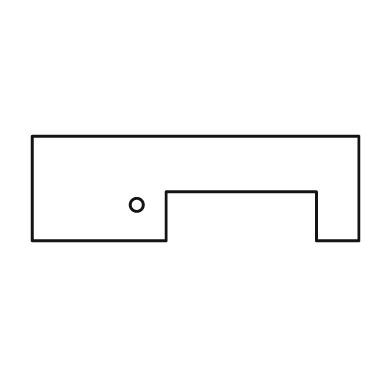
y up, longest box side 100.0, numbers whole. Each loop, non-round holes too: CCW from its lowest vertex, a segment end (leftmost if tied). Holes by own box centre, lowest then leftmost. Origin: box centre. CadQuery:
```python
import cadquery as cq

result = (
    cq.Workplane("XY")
    .moveTo(-50.0, -16.0)
    .lineTo(-9.0, -16.0)
    .lineTo(-9.0, -1.0)
    .lineTo(37.0, -1.0)
    .lineTo(37.0, -16.0)
    .lineTo(50.0, -16.0)
    .lineTo(50.0, 16.0)
    .lineTo(-50.0, 16.0)
    .close()
    .moveTo(-18.0, -5.0)
    .circle(2.0)
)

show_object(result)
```